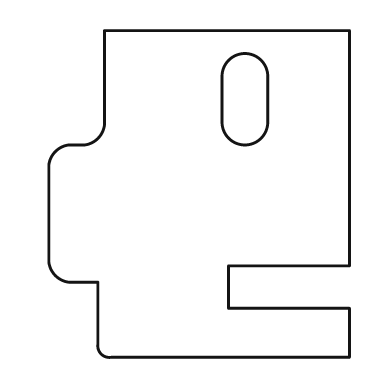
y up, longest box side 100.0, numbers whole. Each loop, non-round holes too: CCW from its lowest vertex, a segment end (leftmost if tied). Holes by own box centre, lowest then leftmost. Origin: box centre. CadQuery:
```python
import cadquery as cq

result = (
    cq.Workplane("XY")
    .moveTo(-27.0, -50.0)
    .lineTo(46.0, -50.0)
    .lineTo(46.0, -35.0)
    .lineTo(9.0, -35.0)
    .lineTo(9.0, -22.0)
    .lineTo(46.0, -22.0)
    .lineTo(46.0, 50.0)
    .lineTo(-29.0, 50.0)
    .lineTo(-29.0, 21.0)
    .threePointArc((-31.0, 17.0), (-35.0, 15.0))
    .lineTo(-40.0, 15.0)
    .threePointArc((-44.0, 13.0), (-46.0, 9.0))
    .lineTo(-46.0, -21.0)
    .threePointArc((-44.0, -25.0), (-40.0, -27.0))
    .lineTo(-31.0, -27.0)
    .lineTo(-31.0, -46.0)
    .threePointArc((-30.0, -49.0), (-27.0, -50.0))
    .close()
    .moveTo(7.0, 22.0)
    .threePointArc((14.0, 15.0), (21.0, 22.0))
    .lineTo(21.0, 36.0)
    .threePointArc((14.0, 43.0), (7.0, 36.0))
    .close()
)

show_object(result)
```